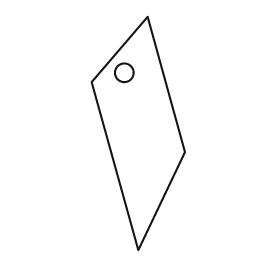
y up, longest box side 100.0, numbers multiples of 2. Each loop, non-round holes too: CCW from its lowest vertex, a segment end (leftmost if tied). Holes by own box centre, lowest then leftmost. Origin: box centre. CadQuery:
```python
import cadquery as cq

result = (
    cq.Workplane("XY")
    .moveTo(0.0, -50.0)
    .lineTo(20.0, -8.0)
    .lineTo(4.0, 50.0)
    .lineTo(-20.0, 22.0)
    .close()
    .moveTo(-6.0, 26.0)
    .circle(4.0)
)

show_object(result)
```